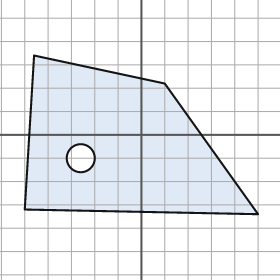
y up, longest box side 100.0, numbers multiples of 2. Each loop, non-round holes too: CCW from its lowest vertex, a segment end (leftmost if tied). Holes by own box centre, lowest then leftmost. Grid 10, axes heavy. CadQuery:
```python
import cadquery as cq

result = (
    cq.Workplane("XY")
    .moveTo(50.0, -34.0)
    .lineTo(10.0, 22.0)
    .lineTo(-46.0, 34.0)
    .lineTo(-50.0, -32.0)
    .close()
    .moveTo(-26.0, -10.0)
    .circle(6.0)
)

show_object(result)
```